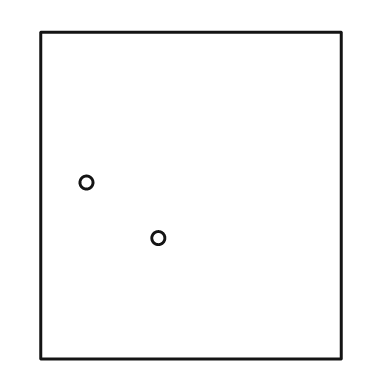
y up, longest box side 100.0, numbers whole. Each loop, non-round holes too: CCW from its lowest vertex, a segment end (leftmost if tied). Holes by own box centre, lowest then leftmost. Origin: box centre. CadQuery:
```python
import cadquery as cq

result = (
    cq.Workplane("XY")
    .moveTo(-46.0, -50.0)
    .lineTo(46.0, -50.0)
    .lineTo(46.0, 50.0)
    .lineTo(-46.0, 50.0)
    .close()
    .moveTo(-10.0, -13.0)
    .circle(2.0)
    .moveTo(-32.0, 4.0)
    .circle(2.0)
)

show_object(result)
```